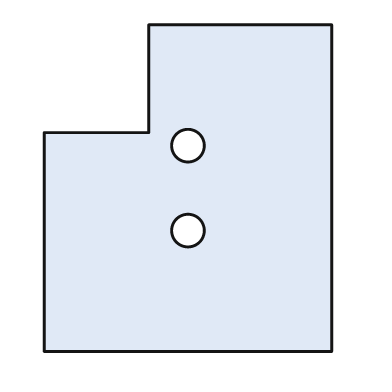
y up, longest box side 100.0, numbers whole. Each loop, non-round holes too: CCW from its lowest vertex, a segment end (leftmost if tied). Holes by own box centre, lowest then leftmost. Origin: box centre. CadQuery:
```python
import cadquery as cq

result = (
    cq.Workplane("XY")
    .moveTo(-44.0, -50.0)
    .lineTo(44.0, -50.0)
    .lineTo(44.0, 50.0)
    .lineTo(-12.0, 50.0)
    .lineTo(-12.0, 17.0)
    .lineTo(-44.0, 17.0)
    .close()
    .moveTo(0.0, -13.0)
    .circle(5.0)
    .moveTo(0.0, 13.0)
    .circle(5.0)
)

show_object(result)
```